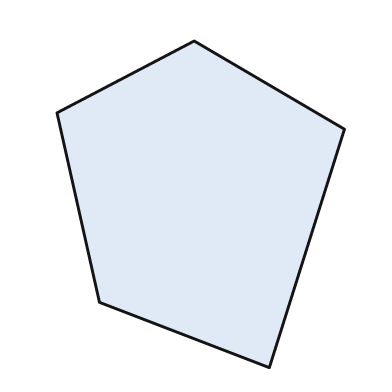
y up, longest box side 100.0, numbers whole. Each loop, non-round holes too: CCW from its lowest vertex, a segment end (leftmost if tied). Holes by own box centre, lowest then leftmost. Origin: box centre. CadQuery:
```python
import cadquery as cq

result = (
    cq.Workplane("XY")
    .moveTo(21.0, -50.0)
    .lineTo(44.0, 23.0)
    .lineTo(-2.0, 50.0)
    .lineTo(-44.0, 28.0)
    .lineTo(-31.0, -30.0)
    .close()
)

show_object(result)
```